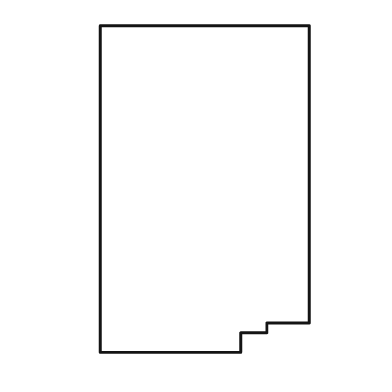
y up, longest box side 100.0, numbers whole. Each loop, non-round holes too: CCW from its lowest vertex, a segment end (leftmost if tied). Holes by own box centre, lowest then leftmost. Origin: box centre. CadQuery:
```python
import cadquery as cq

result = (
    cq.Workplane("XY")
    .moveTo(-32.0, -50.0)
    .lineTo(11.0, -50.0)
    .lineTo(11.0, -44.0)
    .lineTo(19.0, -44.0)
    .lineTo(19.0, -41.0)
    .lineTo(32.0, -41.0)
    .lineTo(32.0, 50.0)
    .lineTo(-32.0, 50.0)
    .close()
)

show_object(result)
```